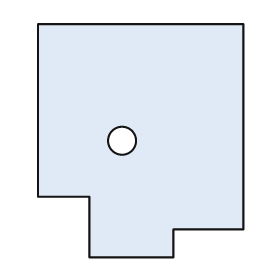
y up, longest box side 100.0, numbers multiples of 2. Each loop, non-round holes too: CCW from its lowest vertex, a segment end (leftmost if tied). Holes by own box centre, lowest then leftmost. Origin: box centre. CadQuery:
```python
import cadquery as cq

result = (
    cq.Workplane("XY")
    .moveTo(-22.0, -50.0)
    .lineTo(14.0, -50.0)
    .lineTo(14.0, -38.0)
    .lineTo(44.0, -38.0)
    .lineTo(44.0, 50.0)
    .lineTo(-44.0, 50.0)
    .lineTo(-44.0, -24.0)
    .lineTo(-22.0, -24.0)
    .close()
    .moveTo(-8.0, 0.0)
    .circle(6.0)
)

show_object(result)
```